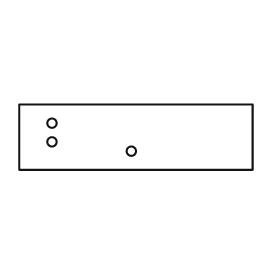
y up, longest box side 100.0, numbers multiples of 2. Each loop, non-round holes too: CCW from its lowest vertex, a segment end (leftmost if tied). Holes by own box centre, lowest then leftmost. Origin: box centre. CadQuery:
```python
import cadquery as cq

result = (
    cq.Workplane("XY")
    .moveTo(-50.0, -14.0)
    .lineTo(50.0, -14.0)
    .lineTo(50.0, 14.0)
    .lineTo(-50.0, 14.0)
    .close()
    .moveTo(-2.0, -6.0)
    .circle(2.0)
    .moveTo(-36.0, -2.0)
    .circle(2.0)
    .moveTo(-36.0, 6.0)
    .circle(2.0)
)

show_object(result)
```